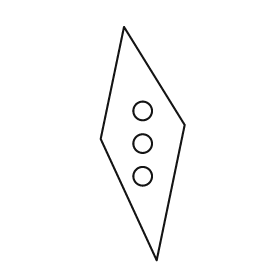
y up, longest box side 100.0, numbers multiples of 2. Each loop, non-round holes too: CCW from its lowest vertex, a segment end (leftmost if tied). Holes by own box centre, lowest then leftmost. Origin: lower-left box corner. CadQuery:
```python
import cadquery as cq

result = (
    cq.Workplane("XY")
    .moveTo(24.0, 0.0)
    .lineTo(36.0, 58.0)
    .lineTo(10.0, 100.0)
    .lineTo(0.0, 52.0)
    .close()
    .moveTo(18.0, 36.0)
    .circle(4.0)
    .moveTo(18.0, 50.0)
    .circle(4.0)
    .moveTo(18.0, 64.0)
    .circle(4.0)
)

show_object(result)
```